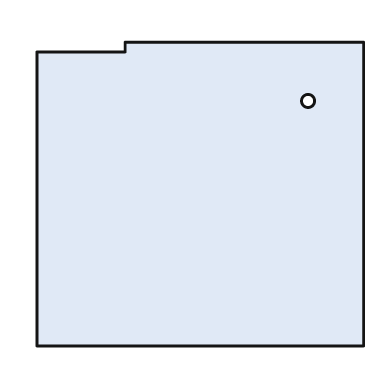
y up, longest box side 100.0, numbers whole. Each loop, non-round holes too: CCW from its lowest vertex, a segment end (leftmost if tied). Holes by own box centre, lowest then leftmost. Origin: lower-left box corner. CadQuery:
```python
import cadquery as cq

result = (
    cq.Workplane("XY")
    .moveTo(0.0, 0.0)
    .lineTo(100.0, 0.0)
    .lineTo(100.0, 93.0)
    .lineTo(27.0, 93.0)
    .lineTo(27.0, 90.0)
    .lineTo(0.0, 90.0)
    .close()
    .moveTo(83.0, 75.0)
    .circle(2.0)
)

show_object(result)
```